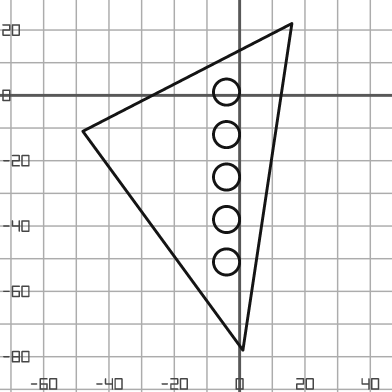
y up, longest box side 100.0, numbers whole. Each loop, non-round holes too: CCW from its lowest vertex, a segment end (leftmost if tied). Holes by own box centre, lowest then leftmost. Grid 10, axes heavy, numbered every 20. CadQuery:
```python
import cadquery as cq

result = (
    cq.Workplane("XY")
    .moveTo(1.0, -78.0)
    .lineTo(16.0, 22.0)
    .lineTo(-48.0, -11.0)
    .close()
    .moveTo(-4.0, -51.0)
    .circle(4.0)
    .moveTo(-4.0, -38.0)
    .circle(4.0)
    .moveTo(-4.0, -25.0)
    .circle(4.0)
    .moveTo(-4.0, -12.0)
    .circle(4.0)
    .moveTo(-4.0, 1.0)
    .circle(4.0)
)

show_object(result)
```